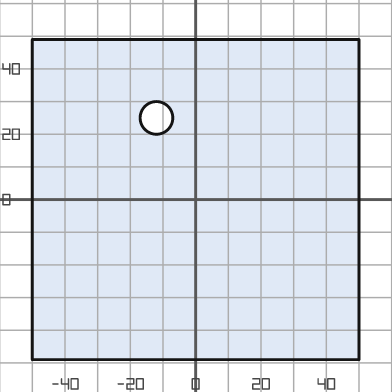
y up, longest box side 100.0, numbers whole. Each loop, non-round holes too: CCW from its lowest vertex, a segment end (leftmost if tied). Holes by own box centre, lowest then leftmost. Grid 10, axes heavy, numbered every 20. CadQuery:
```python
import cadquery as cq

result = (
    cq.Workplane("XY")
    .moveTo(-50.0, -49.0)
    .lineTo(50.0, -49.0)
    .lineTo(50.0, 49.0)
    .lineTo(-50.0, 49.0)
    .close()
    .moveTo(-12.0, 25.0)
    .circle(5.0)
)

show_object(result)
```